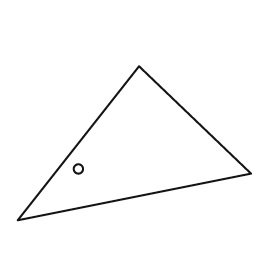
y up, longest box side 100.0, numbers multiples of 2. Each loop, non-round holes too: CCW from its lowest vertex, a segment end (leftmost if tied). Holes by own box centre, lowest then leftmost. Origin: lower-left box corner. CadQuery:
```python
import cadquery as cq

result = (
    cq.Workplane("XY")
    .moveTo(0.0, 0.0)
    .lineTo(100.0, 20.0)
    .lineTo(52.0, 66.0)
    .close()
    .moveTo(26.0, 22.0)
    .circle(2.0)
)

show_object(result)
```